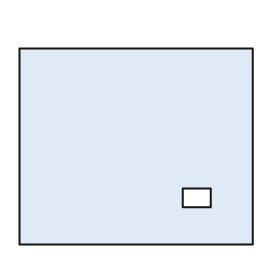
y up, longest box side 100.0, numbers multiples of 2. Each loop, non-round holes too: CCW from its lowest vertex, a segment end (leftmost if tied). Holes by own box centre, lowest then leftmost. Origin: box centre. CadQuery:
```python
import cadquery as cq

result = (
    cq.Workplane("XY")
    .moveTo(-50.0, -42.0)
    .lineTo(50.0, -42.0)
    .lineTo(50.0, 42.0)
    .lineTo(-50.0, 42.0)
    .close()
    .moveTo(20.0, -26.0)
    .lineTo(32.0, -26.0)
    .lineTo(32.0, -18.0)
    .lineTo(20.0, -18.0)
    .close()
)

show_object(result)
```